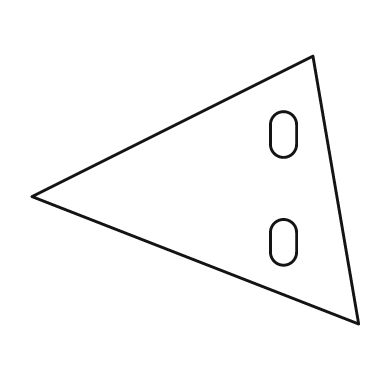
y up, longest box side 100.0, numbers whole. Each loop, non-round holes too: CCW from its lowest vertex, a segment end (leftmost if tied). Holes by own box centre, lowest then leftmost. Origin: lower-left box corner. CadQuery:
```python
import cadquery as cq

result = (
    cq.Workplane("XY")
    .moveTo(100.0, 0.0)
    .lineTo(86.0, 82.0)
    .lineTo(0.0, 39.0)
    .close()
    .moveTo(73.0, 22.0)
    .threePointArc((77.0, 18.0), (81.0, 22.0))
    .lineTo(81.0, 28.0)
    .threePointArc((77.0, 32.0), (73.0, 28.0))
    .close()
    .moveTo(73.0, 55.0)
    .threePointArc((77.0, 51.0), (81.0, 55.0))
    .lineTo(81.0, 61.0)
    .threePointArc((77.0, 65.0), (73.0, 61.0))
    .close()
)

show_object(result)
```